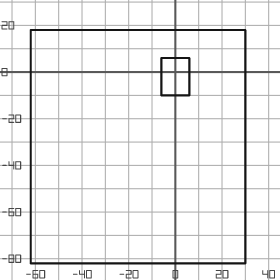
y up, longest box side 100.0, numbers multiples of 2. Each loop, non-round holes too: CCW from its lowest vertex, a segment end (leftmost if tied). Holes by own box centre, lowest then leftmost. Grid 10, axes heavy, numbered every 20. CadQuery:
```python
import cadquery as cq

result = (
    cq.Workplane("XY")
    .moveTo(-62.0, -82.0)
    .lineTo(30.0, -82.0)
    .lineTo(30.0, 18.0)
    .lineTo(-62.0, 18.0)
    .close()
    .moveTo(-6.0, -10.0)
    .lineTo(6.0, -10.0)
    .lineTo(6.0, 6.0)
    .lineTo(-6.0, 6.0)
    .close()
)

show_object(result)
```